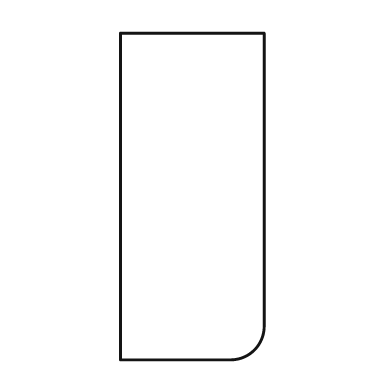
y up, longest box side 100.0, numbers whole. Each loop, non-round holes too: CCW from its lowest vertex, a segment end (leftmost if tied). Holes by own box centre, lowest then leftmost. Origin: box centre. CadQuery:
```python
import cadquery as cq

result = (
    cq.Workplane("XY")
    .moveTo(-22.0, -50.0)
    .lineTo(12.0, -50.0)
    .threePointArc((19.0, -47.0), (22.0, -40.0))
    .lineTo(22.0, 50.0)
    .lineTo(-22.0, 50.0)
    .close()
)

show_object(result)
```